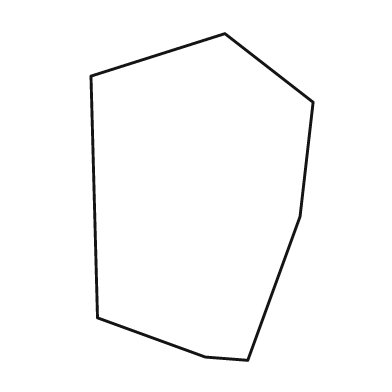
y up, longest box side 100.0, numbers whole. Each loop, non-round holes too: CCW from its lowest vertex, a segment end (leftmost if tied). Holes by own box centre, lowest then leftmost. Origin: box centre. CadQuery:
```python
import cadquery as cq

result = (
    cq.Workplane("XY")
    .moveTo(14.0, -50.0)
    .lineTo(30.0, -6.0)
    .lineTo(34.0, 29.0)
    .lineTo(7.0, 50.0)
    .lineTo(-34.0, 37.0)
    .lineTo(-32.0, -37.0)
    .lineTo(1.0, -49.0)
    .close()
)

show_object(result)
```